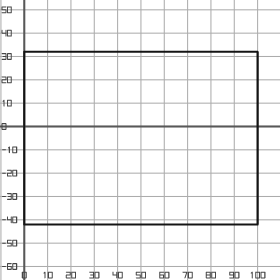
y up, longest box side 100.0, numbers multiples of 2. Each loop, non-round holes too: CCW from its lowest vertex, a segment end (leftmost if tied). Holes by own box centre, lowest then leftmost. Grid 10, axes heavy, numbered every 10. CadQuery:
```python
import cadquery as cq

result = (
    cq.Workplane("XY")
    .moveTo(0.0, -42.0)
    .lineTo(100.0, -42.0)
    .lineTo(100.0, 32.0)
    .lineTo(0.0, 32.0)
    .close()
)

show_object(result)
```